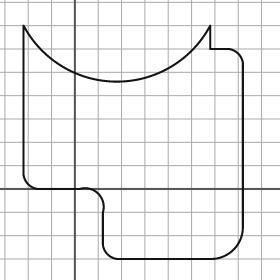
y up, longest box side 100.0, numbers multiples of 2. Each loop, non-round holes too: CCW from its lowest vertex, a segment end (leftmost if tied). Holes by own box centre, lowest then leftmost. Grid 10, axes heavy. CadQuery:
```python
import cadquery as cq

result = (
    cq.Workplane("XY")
    .moveTo(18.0, -30.0)
    .lineTo(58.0, -30.0)
    .threePointArc((68.0, -26.0), (72.0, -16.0))
    .lineTo(72.0, 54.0)
    .threePointArc((70.0, 58.0), (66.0, 60.0))
    .lineTo(58.0, 60.0)
    .lineTo(58.0, 70.0)
    .threePointArc((18.0, 46.0), (-22.0, 70.0))
    .lineTo(-22.0, 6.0)
    .threePointArc((-20.0, 2.0), (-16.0, 0.0))
    .lineTo(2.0, 0.0)
    .threePointArc((10.0, -2.0), (12.0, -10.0))
    .lineTo(12.0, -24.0)
    .threePointArc((14.0, -28.0), (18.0, -30.0))
    .close()
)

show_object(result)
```